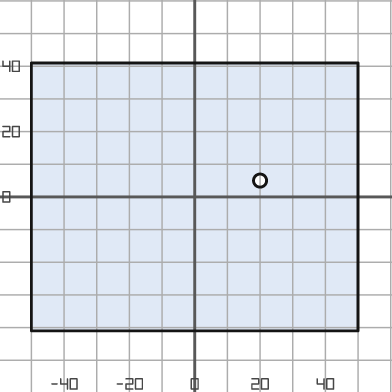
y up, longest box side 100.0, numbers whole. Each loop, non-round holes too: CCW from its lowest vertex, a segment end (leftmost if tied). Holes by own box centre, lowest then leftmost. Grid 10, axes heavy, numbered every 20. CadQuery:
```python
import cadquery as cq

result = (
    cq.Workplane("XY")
    .moveTo(-50.0, -41.0)
    .lineTo(50.0, -41.0)
    .lineTo(50.0, 41.0)
    .lineTo(-50.0, 41.0)
    .close()
    .moveTo(20.0, 5.0)
    .circle(2.0)
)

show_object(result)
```